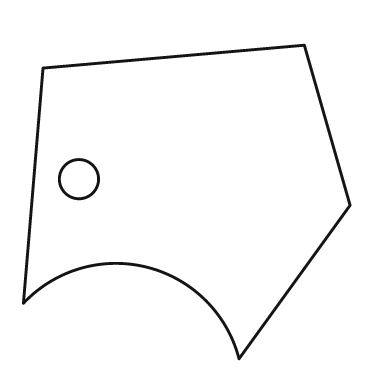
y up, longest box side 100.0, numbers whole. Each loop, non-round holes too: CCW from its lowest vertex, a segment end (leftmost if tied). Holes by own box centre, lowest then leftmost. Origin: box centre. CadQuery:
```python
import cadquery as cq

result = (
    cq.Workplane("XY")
    .moveTo(16.0, -48.0)
    .lineTo(50.0, -1.0)
    .lineTo(36.0, 48.0)
    .lineTo(-44.0, 41.0)
    .lineTo(-50.0, -31.0)
    .threePointArc((-12.0, -20.0), (16.0, -48.0))
    .close()
    .moveTo(-33.0, 7.0)
    .circle(6.0)
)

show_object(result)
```